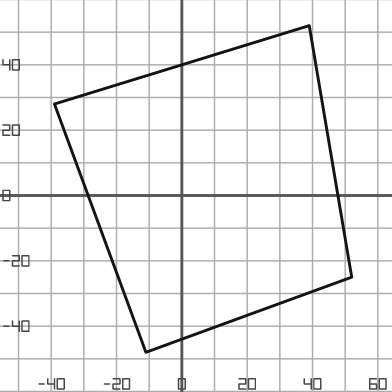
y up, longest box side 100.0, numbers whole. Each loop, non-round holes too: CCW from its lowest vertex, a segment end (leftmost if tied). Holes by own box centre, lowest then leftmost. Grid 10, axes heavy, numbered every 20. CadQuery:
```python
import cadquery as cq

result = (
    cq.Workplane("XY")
    .moveTo(-11.0, -48.0)
    .lineTo(52.0, -25.0)
    .lineTo(39.0, 52.0)
    .lineTo(-39.0, 28.0)
    .close()
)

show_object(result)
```